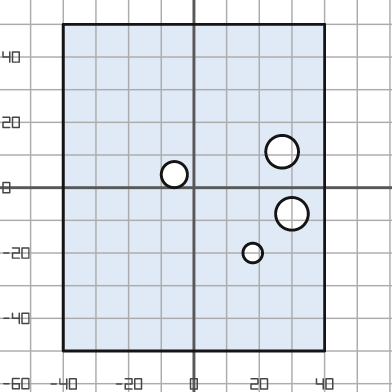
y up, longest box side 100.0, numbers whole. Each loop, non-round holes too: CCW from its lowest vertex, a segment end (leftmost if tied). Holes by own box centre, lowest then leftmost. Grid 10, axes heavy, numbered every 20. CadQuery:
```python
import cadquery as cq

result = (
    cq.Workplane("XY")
    .moveTo(-40.0, -50.0)
    .lineTo(40.0, -50.0)
    .lineTo(40.0, 50.0)
    .lineTo(-40.0, 50.0)
    .close()
    .moveTo(18.0, -20.0)
    .circle(3.0)
    .moveTo(30.0, -8.0)
    .circle(5.0)
    .moveTo(-6.0, 4.0)
    .circle(4.0)
    .moveTo(27.0, 11.0)
    .circle(5.0)
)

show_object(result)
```